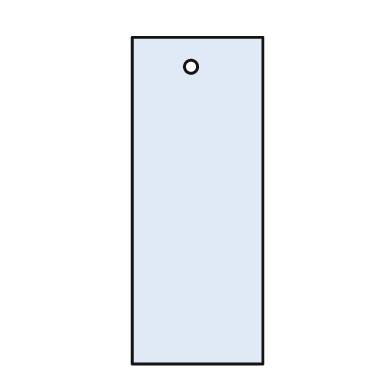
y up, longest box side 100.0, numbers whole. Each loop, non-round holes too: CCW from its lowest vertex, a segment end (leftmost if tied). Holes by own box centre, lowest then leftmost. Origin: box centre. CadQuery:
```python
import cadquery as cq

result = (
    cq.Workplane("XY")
    .moveTo(-20.0, -50.0)
    .lineTo(20.0, -50.0)
    .lineTo(20.0, 50.0)
    .lineTo(-20.0, 50.0)
    .close()
    .moveTo(-2.0, 41.0)
    .circle(2.0)
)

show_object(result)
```